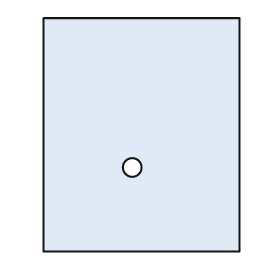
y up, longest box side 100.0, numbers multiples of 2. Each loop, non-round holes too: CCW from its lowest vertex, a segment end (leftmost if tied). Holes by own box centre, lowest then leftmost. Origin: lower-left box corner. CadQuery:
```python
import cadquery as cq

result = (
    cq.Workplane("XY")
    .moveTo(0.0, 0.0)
    .lineTo(84.0, 0.0)
    .lineTo(84.0, 100.0)
    .lineTo(0.0, 100.0)
    .close()
    .moveTo(38.0, 36.0)
    .circle(4.0)
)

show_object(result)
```